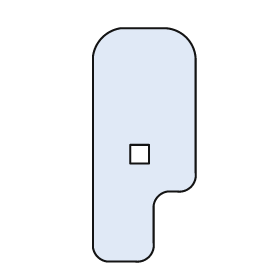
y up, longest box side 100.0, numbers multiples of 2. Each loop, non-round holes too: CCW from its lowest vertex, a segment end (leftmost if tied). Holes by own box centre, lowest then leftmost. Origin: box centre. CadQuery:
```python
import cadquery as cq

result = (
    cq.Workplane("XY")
    .moveTo(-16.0, -50.0)
    .lineTo(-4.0, -50.0)
    .threePointArc((2.0, -48.0), (4.0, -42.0))
    .lineTo(4.0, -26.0)
    .threePointArc((6.0, -22.0), (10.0, -20.0))
    .lineTo(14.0, -20.0)
    .threePointArc((20.0, -18.0), (22.0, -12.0))
    .lineTo(22.0, 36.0)
    .threePointArc((18.0, 46.0), (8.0, 50.0))
    .lineTo(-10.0, 50.0)
    .threePointArc((-18.0, 46.0), (-22.0, 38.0))
    .lineTo(-22.0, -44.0)
    .threePointArc((-20.0, -48.0), (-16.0, -50.0))
    .close()
    .moveTo(-6.0, -8.0)
    .lineTo(2.0, -8.0)
    .lineTo(2.0, 0.0)
    .lineTo(-6.0, 0.0)
    .close()
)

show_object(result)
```